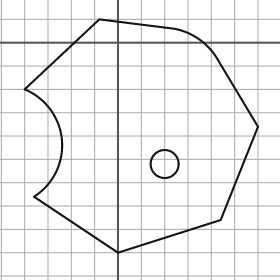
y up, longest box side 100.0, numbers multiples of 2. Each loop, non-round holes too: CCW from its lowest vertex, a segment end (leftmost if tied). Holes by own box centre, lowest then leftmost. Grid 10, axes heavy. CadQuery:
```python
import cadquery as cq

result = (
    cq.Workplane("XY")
    .moveTo(0.0, -90.0)
    .lineTo(44.0, -76.0)
    .lineTo(60.0, -36.0)
    .lineTo(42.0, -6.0)
    .threePointArc((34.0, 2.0), (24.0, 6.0))
    .lineTo(-8.0, 10.0)
    .lineTo(-40.0, -20.0)
    .threePointArc((-24.0, -42.0), (-36.0, -66.0))
    .close()
    .moveTo(20.0, -52.0)
    .circle(6.0)
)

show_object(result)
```